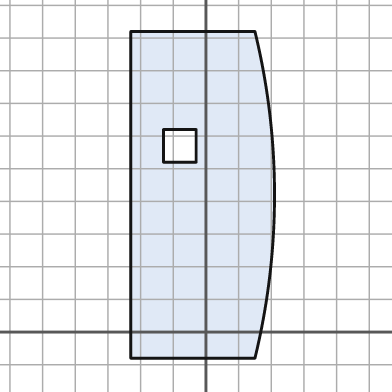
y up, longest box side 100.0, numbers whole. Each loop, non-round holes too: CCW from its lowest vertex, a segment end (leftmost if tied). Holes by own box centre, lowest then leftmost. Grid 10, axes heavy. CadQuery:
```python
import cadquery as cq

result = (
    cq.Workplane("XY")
    .moveTo(-23.0, -8.0)
    .lineTo(15.0, -8.0)
    .threePointArc((21.0, 42.0), (15.0, 92.0))
    .lineTo(-23.0, 92.0)
    .close()
    .moveTo(-13.0, 52.0)
    .lineTo(-3.0, 52.0)
    .lineTo(-3.0, 62.0)
    .lineTo(-13.0, 62.0)
    .close()
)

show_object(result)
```